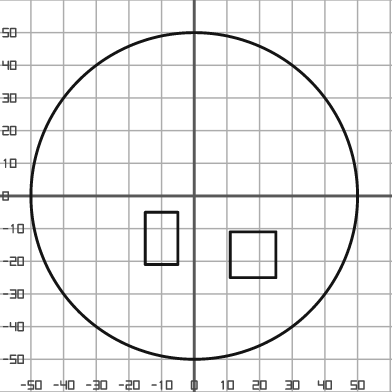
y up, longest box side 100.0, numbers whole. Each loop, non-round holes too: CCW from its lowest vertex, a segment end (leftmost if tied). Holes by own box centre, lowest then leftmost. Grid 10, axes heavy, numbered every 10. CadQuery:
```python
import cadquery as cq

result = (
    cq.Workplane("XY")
    .moveTo(0.0, 0.0)
    .circle(50.0)
    .moveTo(11.0, -25.0)
    .lineTo(25.0, -25.0)
    .lineTo(25.0, -11.0)
    .lineTo(11.0, -11.0)
    .close()
    .moveTo(-15.0, -21.0)
    .lineTo(-5.0, -21.0)
    .lineTo(-5.0, -5.0)
    .lineTo(-15.0, -5.0)
    .close()
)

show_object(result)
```